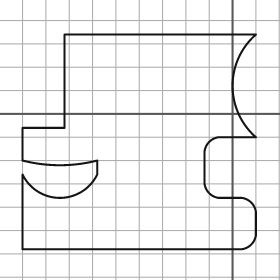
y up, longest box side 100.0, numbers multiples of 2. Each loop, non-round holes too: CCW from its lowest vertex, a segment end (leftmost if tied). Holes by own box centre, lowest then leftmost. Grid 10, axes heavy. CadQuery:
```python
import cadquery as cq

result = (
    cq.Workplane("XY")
    .moveTo(-90.0, -58.0)
    .lineTo(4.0, -58.0)
    .threePointArc((8.0, -56.0), (10.0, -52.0))
    .lineTo(10.0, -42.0)
    .threePointArc((8.0, -38.0), (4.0, -36.0))
    .lineTo(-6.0, -36.0)
    .threePointArc((-10.0, -34.0), (-12.0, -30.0))
    .lineTo(-12.0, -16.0)
    .threePointArc((-10.0, -12.0), (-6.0, -10.0))
    .lineTo(10.0, -10.0)
    .threePointArc((0.0, 12.0), (10.0, 34.0))
    .lineTo(-72.0, 34.0)
    .lineTo(-72.0, -6.0)
    .lineTo(-90.0, -6.0)
    .lineTo(-90.0, -20.0)
    .threePointArc((-74.0, -22.0), (-58.0, -20.0))
    .lineTo(-58.0, -26.0)
    .threePointArc((-74.0, -36.0), (-90.0, -26.0))
    .close()
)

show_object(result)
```